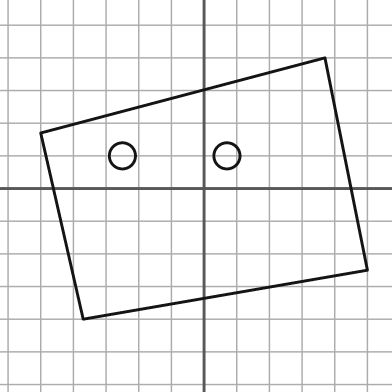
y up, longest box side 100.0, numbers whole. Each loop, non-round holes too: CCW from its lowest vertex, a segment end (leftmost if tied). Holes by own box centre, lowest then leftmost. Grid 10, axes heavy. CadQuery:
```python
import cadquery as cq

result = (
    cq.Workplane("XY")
    .moveTo(-37.0, -40.0)
    .lineTo(50.0, -25.0)
    .lineTo(37.0, 40.0)
    .lineTo(-50.0, 17.0)
    .close()
    .moveTo(-25.0, 10.0)
    .circle(4.0)
    .moveTo(7.0, 10.0)
    .circle(4.0)
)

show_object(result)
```